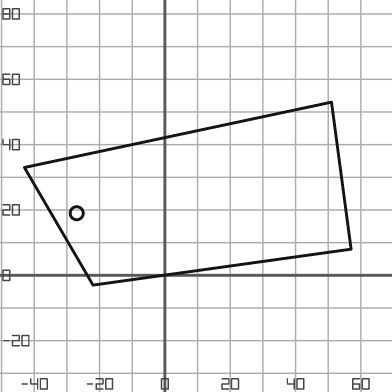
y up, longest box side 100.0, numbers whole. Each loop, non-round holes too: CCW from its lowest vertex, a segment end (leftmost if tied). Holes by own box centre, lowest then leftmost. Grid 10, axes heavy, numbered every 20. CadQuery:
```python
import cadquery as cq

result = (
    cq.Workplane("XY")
    .moveTo(-22.0, -3.0)
    .lineTo(57.0, 8.0)
    .lineTo(51.0, 53.0)
    .lineTo(-43.0, 33.0)
    .close()
    .moveTo(-27.0, 19.0)
    .circle(2.0)
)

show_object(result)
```